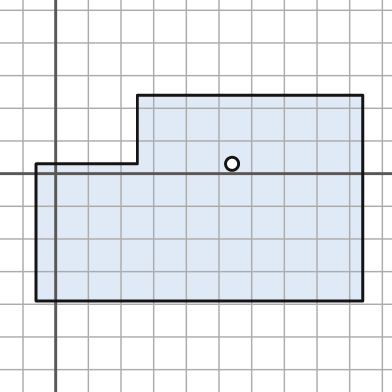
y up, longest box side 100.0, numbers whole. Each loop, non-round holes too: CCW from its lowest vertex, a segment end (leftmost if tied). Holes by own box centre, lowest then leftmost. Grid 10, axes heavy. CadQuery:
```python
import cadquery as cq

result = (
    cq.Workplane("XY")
    .moveTo(-6.0, -39.0)
    .lineTo(94.0, -39.0)
    .lineTo(94.0, 24.0)
    .lineTo(25.0, 24.0)
    .lineTo(25.0, 3.0)
    .lineTo(-6.0, 3.0)
    .close()
    .moveTo(54.0, 3.0)
    .circle(2.0)
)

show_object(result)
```